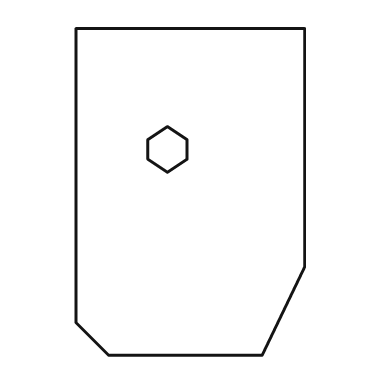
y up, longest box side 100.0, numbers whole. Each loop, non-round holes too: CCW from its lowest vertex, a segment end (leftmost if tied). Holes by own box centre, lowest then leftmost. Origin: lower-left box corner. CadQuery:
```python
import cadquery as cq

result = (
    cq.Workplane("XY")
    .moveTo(10.0, 0.0)
    .lineTo(57.0, 0.0)
    .lineTo(70.0, 27.0)
    .lineTo(70.0, 100.0)
    .lineTo(0.0, 100.0)
    .lineTo(0.0, 10.0)
    .close()
    .moveTo(28.0, 56.0)
    .lineTo(34.0, 60.0)
    .lineTo(34.0, 66.0)
    .lineTo(28.0, 70.0)
    .lineTo(22.0, 66.0)
    .lineTo(22.0, 60.0)
    .close()
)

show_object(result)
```